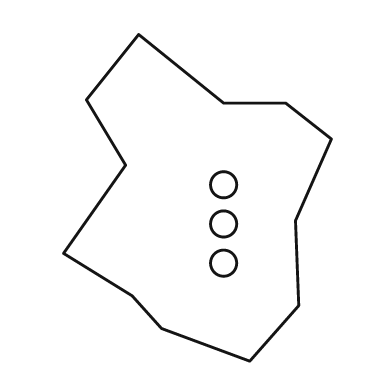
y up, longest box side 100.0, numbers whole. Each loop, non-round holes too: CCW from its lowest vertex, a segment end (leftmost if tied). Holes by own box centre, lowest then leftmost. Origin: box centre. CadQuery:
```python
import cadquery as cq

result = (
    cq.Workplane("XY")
    .moveTo(16.0, -50.0)
    .lineTo(31.0, -33.0)
    .lineTo(30.0, -7.0)
    .lineTo(41.0, 18.0)
    .lineTo(27.0, 29.0)
    .lineTo(8.0, 29.0)
    .lineTo(-18.0, 50.0)
    .lineTo(-34.0, 30.0)
    .lineTo(-22.0, 10.0)
    .lineTo(-41.0, -17.0)
    .lineTo(-20.0, -30.0)
    .lineTo(-11.0, -40.0)
    .close()
    .moveTo(8.0, -20.0)
    .circle(4.0)
    .moveTo(8.0, -8.0)
    .circle(4.0)
    .moveTo(8.0, 4.0)
    .circle(4.0)
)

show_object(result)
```